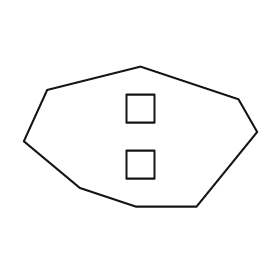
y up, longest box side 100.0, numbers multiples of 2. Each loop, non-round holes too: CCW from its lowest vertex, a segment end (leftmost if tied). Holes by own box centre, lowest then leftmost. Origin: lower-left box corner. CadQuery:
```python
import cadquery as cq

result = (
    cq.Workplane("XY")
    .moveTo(48.0, 0.0)
    .lineTo(74.0, 0.0)
    .lineTo(100.0, 32.0)
    .lineTo(92.0, 46.0)
    .lineTo(50.0, 60.0)
    .lineTo(10.0, 50.0)
    .lineTo(0.0, 28.0)
    .lineTo(24.0, 8.0)
    .close()
    .moveTo(44.0, 12.0)
    .lineTo(56.0, 12.0)
    .lineTo(56.0, 24.0)
    .lineTo(44.0, 24.0)
    .close()
    .moveTo(44.0, 36.0)
    .lineTo(56.0, 36.0)
    .lineTo(56.0, 48.0)
    .lineTo(44.0, 48.0)
    .close()
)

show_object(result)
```